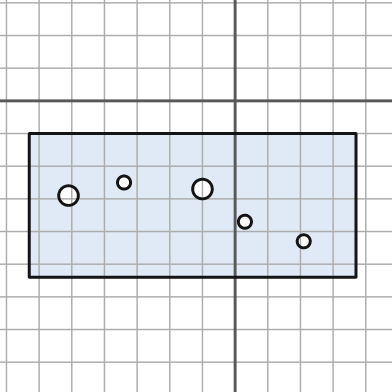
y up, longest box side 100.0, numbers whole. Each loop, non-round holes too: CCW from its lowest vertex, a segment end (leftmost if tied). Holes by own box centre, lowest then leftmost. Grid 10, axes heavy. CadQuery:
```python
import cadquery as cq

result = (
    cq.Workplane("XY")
    .moveTo(-63.0, -54.0)
    .lineTo(37.0, -54.0)
    .lineTo(37.0, -10.0)
    .lineTo(-63.0, -10.0)
    .close()
    .moveTo(21.0, -43.0)
    .circle(2.0)
    .moveTo(3.0, -37.0)
    .circle(2.0)
    .moveTo(-51.0, -29.0)
    .circle(3.0)
    .moveTo(-10.0, -27.0)
    .circle(3.0)
    .moveTo(-34.0, -25.0)
    .circle(2.0)
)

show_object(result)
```